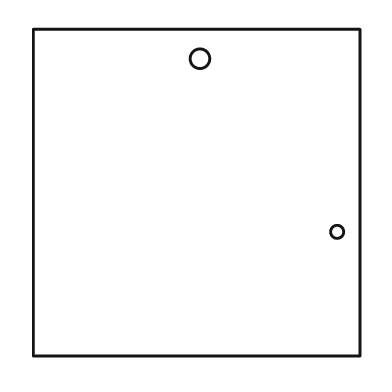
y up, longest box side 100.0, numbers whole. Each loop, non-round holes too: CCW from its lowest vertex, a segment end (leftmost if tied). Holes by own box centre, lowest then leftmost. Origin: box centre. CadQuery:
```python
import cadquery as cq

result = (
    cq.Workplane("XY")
    .moveTo(-50.0, -50.0)
    .lineTo(50.0, -50.0)
    .lineTo(50.0, 50.0)
    .lineTo(-50.0, 50.0)
    .close()
    .moveTo(43.0, -12.0)
    .circle(2.0)
    .moveTo(1.0, 41.0)
    .circle(3.0)
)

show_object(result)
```